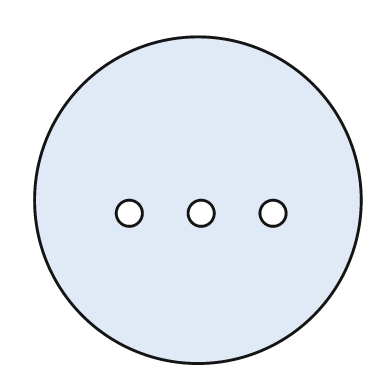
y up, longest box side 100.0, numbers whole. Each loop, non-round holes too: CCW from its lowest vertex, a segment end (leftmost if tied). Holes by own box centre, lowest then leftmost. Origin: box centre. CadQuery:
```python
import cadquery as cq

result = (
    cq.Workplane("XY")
    .moveTo(0.0, 0.0)
    .circle(50.0)
    .moveTo(-21.0, -4.0)
    .circle(4.0)
    .moveTo(1.0, -4.0)
    .circle(4.0)
    .moveTo(23.0, -4.0)
    .circle(4.0)
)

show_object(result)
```